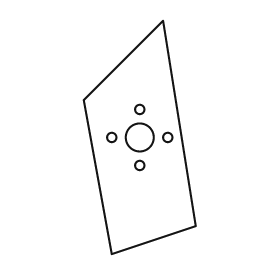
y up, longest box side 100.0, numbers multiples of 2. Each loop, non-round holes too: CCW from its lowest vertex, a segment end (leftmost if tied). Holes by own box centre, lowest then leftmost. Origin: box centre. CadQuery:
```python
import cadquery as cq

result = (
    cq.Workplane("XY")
    .moveTo(-12.0, -50.0)
    .lineTo(24.0, -38.0)
    .lineTo(10.0, 50.0)
    .lineTo(-24.0, 16.0)
    .close()
    .moveTo(0.0, -12.0)
    .circle(2.0)
    .moveTo(-12.0, 0.0)
    .circle(2.0)
    .moveTo(0.0, 0.0)
    .circle(6.0)
    .moveTo(12.0, 0.0)
    .circle(2.0)
    .moveTo(0.0, 12.0)
    .circle(2.0)
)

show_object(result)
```